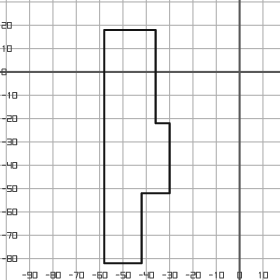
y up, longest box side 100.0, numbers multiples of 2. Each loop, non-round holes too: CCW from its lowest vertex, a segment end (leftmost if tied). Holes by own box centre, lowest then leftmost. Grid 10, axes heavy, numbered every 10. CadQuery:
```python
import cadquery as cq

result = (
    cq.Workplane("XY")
    .moveTo(-58.0, -82.0)
    .lineTo(-42.0, -82.0)
    .lineTo(-42.0, -52.0)
    .lineTo(-30.0, -52.0)
    .lineTo(-30.0, -22.0)
    .lineTo(-36.0, -22.0)
    .lineTo(-36.0, 18.0)
    .lineTo(-58.0, 18.0)
    .close()
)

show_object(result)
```